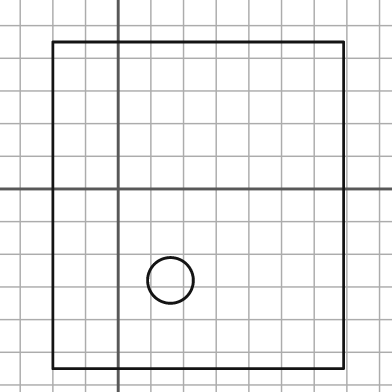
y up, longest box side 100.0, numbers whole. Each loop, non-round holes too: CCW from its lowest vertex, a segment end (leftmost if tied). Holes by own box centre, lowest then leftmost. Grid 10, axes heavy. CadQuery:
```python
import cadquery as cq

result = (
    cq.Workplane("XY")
    .moveTo(-20.0, -55.0)
    .lineTo(69.0, -55.0)
    .lineTo(69.0, 45.0)
    .lineTo(-20.0, 45.0)
    .close()
    .moveTo(16.0, -28.0)
    .circle(7.0)
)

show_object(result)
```